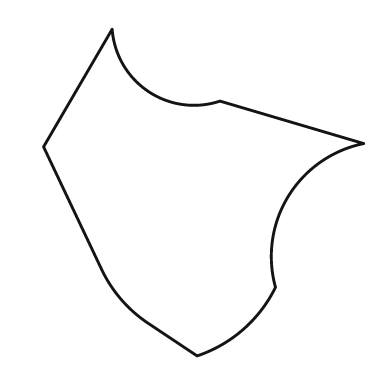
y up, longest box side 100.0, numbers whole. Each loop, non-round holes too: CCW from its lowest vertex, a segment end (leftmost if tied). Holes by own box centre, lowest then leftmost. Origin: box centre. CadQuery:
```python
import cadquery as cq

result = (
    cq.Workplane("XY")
    .moveTo(-2.0, -50.0)
    .threePointArc((12.0, -42.0), (22.0, -29.0))
    .threePointArc((26.0, -1.0), (49.0, 15.0))
    .lineTo(5.0, 28.0)
    .threePointArc((-17.0, 31.0), (-28.0, 50.0))
    .lineTo(-49.0, 14.0)
    .lineTo(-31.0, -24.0)
    .threePointArc((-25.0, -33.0), (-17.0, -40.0))
    .close()
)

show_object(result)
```